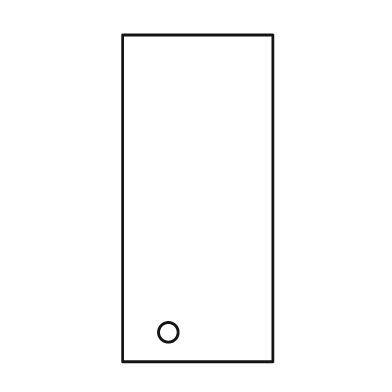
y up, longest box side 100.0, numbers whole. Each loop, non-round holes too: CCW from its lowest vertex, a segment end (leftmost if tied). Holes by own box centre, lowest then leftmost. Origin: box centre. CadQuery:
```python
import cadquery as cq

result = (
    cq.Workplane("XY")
    .moveTo(-23.0, -50.0)
    .lineTo(23.0, -50.0)
    .lineTo(23.0, 50.0)
    .lineTo(-23.0, 50.0)
    .close()
    .moveTo(-9.0, -41.0)
    .circle(3.0)
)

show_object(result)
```